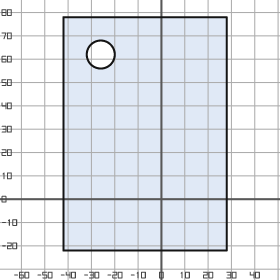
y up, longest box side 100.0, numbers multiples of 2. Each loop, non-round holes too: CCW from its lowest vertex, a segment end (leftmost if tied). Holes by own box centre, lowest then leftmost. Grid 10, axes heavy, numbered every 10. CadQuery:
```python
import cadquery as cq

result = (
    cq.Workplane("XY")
    .moveTo(-42.0, -22.0)
    .lineTo(28.0, -22.0)
    .lineTo(28.0, 78.0)
    .lineTo(-42.0, 78.0)
    .close()
    .moveTo(-26.0, 62.0)
    .circle(6.0)
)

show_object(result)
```